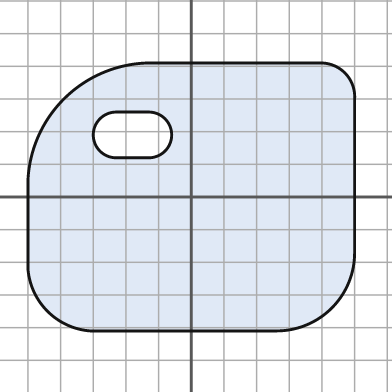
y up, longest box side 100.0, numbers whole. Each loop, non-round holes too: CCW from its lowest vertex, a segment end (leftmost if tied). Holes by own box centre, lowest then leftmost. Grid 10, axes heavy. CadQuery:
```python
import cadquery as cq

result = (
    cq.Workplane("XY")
    .moveTo(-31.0, -41.0)
    .lineTo(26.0, -41.0)
    .threePointArc((43.0, -34.0), (50.0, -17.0))
    .lineTo(50.0, 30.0)
    .threePointArc((47.0, 38.0), (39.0, 41.0))
    .lineTo(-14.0, 41.0)
    .threePointArc((-39.0, 30.0), (-50.0, 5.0))
    .lineTo(-50.0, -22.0)
    .threePointArc((-44.0, -35.0), (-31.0, -41.0))
    .close()
    .moveTo(-23.0, 12.0)
    .lineTo(-13.0, 12.0)
    .threePointArc((-6.0, 19.0), (-13.0, 26.0))
    .lineTo(-23.0, 26.0)
    .threePointArc((-30.0, 19.0), (-23.0, 12.0))
    .close()
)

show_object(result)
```